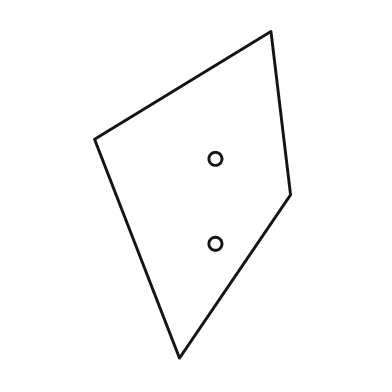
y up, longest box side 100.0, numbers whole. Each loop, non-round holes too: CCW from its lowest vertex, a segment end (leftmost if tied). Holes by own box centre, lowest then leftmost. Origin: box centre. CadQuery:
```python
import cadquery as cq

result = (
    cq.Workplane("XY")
    .moveTo(-4.0, -50.0)
    .lineTo(30.0, 0.0)
    .lineTo(24.0, 50.0)
    .lineTo(-30.0, 17.0)
    .close()
    .moveTo(7.0, -15.0)
    .circle(2.0)
    .moveTo(7.0, 11.0)
    .circle(2.0)
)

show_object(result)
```